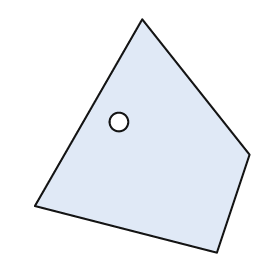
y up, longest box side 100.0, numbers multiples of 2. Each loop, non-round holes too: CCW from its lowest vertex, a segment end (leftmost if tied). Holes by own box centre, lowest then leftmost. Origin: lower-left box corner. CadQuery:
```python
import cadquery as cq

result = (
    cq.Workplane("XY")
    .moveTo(78.0, 0.0)
    .lineTo(92.0, 42.0)
    .lineTo(46.0, 100.0)
    .lineTo(0.0, 20.0)
    .close()
    .moveTo(36.0, 56.0)
    .circle(4.0)
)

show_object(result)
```